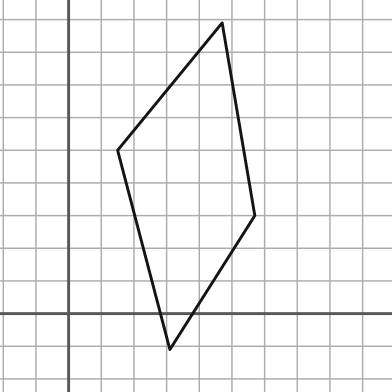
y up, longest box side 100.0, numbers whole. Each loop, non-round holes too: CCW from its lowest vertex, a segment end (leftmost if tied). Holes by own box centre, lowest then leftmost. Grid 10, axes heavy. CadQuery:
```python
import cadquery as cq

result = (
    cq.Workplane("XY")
    .moveTo(31.0, -11.0)
    .lineTo(57.0, 30.0)
    .lineTo(47.0, 89.0)
    .lineTo(15.0, 50.0)
    .close()
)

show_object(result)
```